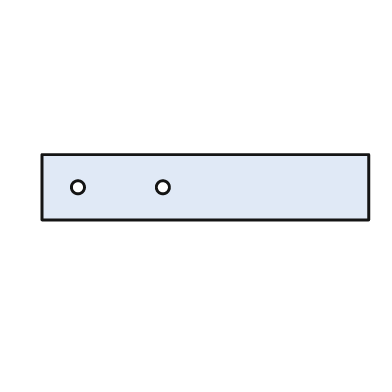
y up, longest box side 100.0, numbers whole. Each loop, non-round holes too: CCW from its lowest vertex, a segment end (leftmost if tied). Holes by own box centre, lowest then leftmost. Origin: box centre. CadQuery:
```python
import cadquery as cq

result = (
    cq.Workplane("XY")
    .moveTo(-50.0, -10.0)
    .lineTo(50.0, -10.0)
    .lineTo(50.0, 10.0)
    .lineTo(-50.0, 10.0)
    .close()
    .moveTo(-39.0, 0.0)
    .circle(2.0)
    .moveTo(-13.0, 0.0)
    .circle(2.0)
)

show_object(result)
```